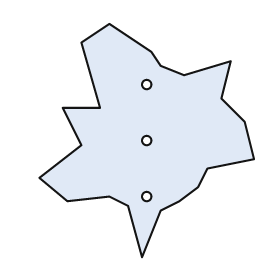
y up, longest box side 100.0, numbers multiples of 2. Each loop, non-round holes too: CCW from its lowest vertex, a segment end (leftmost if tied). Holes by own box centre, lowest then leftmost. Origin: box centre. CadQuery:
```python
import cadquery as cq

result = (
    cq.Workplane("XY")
    .moveTo(-2.0, -50.0)
    .lineTo(6.0, -30.0)
    .lineTo(14.0, -26.0)
    .lineTo(22.0, -20.0)
    .lineTo(26.0, -12.0)
    .lineTo(46.0, -8.0)
    .lineTo(42.0, 8.0)
    .lineTo(32.0, 18.0)
    .lineTo(36.0, 34.0)
    .lineTo(16.0, 28.0)
    .lineTo(6.0, 32.0)
    .lineTo(2.0, 38.0)
    .lineTo(-16.0, 50.0)
    .lineTo(-28.0, 42.0)
    .lineTo(-20.0, 14.0)
    .lineTo(-36.0, 14.0)
    .lineTo(-28.0, -2.0)
    .lineTo(-46.0, -16.0)
    .lineTo(-34.0, -26.0)
    .lineTo(-16.0, -24.0)
    .lineTo(-8.0, -28.0)
    .close()
    .moveTo(0.0, -24.0)
    .circle(2.0)
    .moveTo(0.0, 0.0)
    .circle(2.0)
    .moveTo(0.0, 24.0)
    .circle(2.0)
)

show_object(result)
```